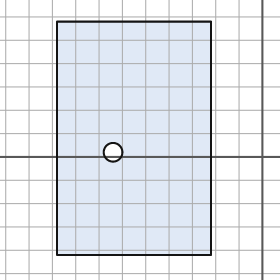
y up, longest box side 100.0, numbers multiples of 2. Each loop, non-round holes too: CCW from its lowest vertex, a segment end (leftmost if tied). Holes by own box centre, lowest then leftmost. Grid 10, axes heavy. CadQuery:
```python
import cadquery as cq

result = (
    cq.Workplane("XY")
    .moveTo(-88.0, -42.0)
    .lineTo(-22.0, -42.0)
    .lineTo(-22.0, 58.0)
    .lineTo(-88.0, 58.0)
    .close()
    .moveTo(-64.0, 2.0)
    .circle(4.0)
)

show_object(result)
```